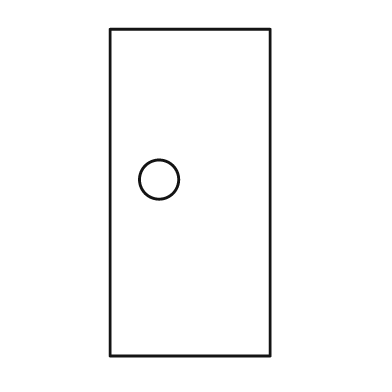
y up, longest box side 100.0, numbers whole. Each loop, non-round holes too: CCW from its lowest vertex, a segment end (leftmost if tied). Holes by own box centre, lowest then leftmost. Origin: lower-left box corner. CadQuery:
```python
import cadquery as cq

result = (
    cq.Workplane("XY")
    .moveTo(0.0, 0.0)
    .lineTo(49.0, 0.0)
    .lineTo(49.0, 100.0)
    .lineTo(0.0, 100.0)
    .close()
    .moveTo(15.0, 54.0)
    .circle(6.0)
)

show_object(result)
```